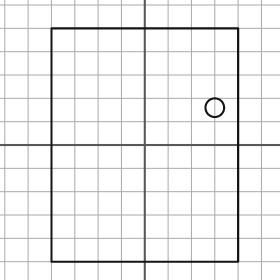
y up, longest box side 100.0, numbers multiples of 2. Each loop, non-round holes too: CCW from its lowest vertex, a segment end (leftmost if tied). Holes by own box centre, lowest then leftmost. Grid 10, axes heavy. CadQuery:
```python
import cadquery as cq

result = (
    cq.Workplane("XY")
    .moveTo(-40.0, -50.0)
    .lineTo(40.0, -50.0)
    .lineTo(40.0, 50.0)
    .lineTo(-40.0, 50.0)
    .close()
    .moveTo(30.0, 16.0)
    .circle(4.0)
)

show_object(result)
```